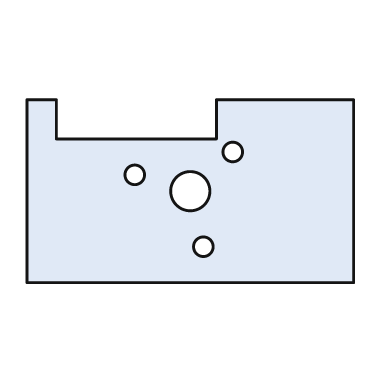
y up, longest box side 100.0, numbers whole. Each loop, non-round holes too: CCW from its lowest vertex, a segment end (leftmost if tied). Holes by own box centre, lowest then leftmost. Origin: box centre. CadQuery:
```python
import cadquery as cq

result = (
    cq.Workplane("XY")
    .moveTo(-50.0, -28.0)
    .lineTo(50.0, -28.0)
    .lineTo(50.0, 28.0)
    .lineTo(8.0, 28.0)
    .lineTo(8.0, 16.0)
    .lineTo(-41.0, 16.0)
    .lineTo(-41.0, 28.0)
    .lineTo(-50.0, 28.0)
    .close()
    .moveTo(4.0, -17.0)
    .circle(3.0)
    .moveTo(0.0, 0.0)
    .circle(6.0)
    .moveTo(-17.0, 5.0)
    .circle(3.0)
    .moveTo(13.0, 12.0)
    .circle(3.0)
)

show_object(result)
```